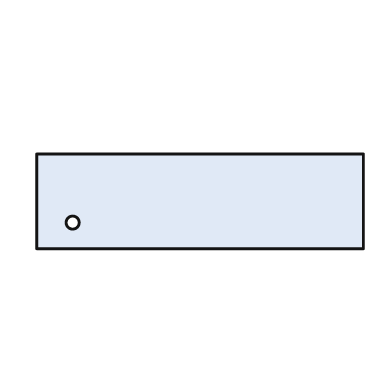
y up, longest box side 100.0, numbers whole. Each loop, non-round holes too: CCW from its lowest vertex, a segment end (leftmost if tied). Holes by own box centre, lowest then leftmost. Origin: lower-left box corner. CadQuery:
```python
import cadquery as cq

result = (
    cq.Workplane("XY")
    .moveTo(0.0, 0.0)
    .lineTo(100.0, 0.0)
    .lineTo(100.0, 29.0)
    .lineTo(0.0, 29.0)
    .close()
    .moveTo(11.0, 8.0)
    .circle(2.0)
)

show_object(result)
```